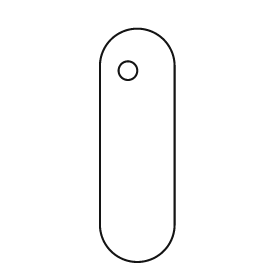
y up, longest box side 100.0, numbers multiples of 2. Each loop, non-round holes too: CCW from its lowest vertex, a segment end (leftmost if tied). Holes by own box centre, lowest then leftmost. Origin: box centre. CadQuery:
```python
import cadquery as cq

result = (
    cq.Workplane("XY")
    .moveTo(-16.0, -34.0)
    .threePointArc((0.0, -50.0), (16.0, -34.0))
    .lineTo(16.0, 34.0)
    .threePointArc((0.0, 50.0), (-16.0, 34.0))
    .close()
    .moveTo(-4.0, 32.0)
    .circle(4.0)
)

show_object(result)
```